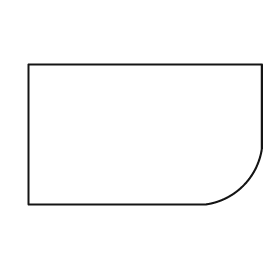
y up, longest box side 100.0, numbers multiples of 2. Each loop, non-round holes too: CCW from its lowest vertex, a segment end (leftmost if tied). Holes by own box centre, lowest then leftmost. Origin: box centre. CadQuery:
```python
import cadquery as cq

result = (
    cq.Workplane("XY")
    .moveTo(-50.0, -30.0)
    .lineTo(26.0, -30.0)
    .threePointArc((42.0, -22.0), (50.0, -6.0))
    .lineTo(50.0, 30.0)
    .lineTo(-50.0, 30.0)
    .close()
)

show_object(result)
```